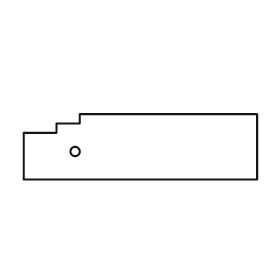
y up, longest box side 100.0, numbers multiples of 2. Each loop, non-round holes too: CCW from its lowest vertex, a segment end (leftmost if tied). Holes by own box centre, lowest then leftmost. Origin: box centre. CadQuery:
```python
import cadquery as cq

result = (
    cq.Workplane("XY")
    .moveTo(-50.0, -14.0)
    .lineTo(50.0, -14.0)
    .lineTo(50.0, 14.0)
    .lineTo(-26.0, 14.0)
    .lineTo(-26.0, 10.0)
    .lineTo(-36.0, 10.0)
    .lineTo(-36.0, 6.0)
    .lineTo(-50.0, 6.0)
    .close()
    .moveTo(-28.0, -2.0)
    .circle(2.0)
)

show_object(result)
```